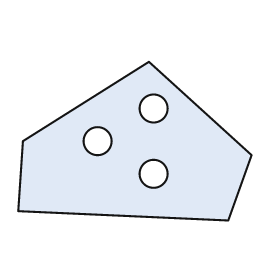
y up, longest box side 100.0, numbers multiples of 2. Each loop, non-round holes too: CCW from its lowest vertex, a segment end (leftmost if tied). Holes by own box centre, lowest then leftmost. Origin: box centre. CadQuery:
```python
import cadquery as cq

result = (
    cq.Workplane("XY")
    .moveTo(40.0, -34.0)
    .lineTo(50.0, -6.0)
    .lineTo(6.0, 34.0)
    .lineTo(-48.0, 0.0)
    .lineTo(-50.0, -30.0)
    .close()
    .moveTo(8.0, -14.0)
    .circle(6.0)
    .moveTo(-16.0, 0.0)
    .circle(6.0)
    .moveTo(8.0, 14.0)
    .circle(6.0)
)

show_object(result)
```